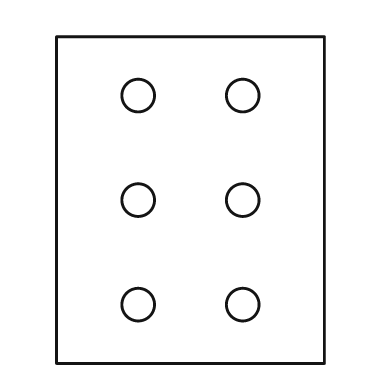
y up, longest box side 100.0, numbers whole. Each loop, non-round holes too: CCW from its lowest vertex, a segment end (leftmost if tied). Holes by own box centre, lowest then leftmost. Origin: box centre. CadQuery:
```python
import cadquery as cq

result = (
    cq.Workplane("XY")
    .moveTo(-41.0, -50.0)
    .lineTo(41.0, -50.0)
    .lineTo(41.0, 50.0)
    .lineTo(-41.0, 50.0)
    .close()
    .moveTo(-16.0, -32.0)
    .circle(5.0)
    .moveTo(16.0, -32.0)
    .circle(5.0)
    .moveTo(-16.0, 0.0)
    .circle(5.0)
    .moveTo(16.0, 0.0)
    .circle(5.0)
    .moveTo(-16.0, 32.0)
    .circle(5.0)
    .moveTo(16.0, 32.0)
    .circle(5.0)
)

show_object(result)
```